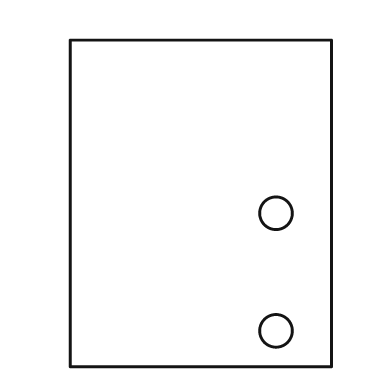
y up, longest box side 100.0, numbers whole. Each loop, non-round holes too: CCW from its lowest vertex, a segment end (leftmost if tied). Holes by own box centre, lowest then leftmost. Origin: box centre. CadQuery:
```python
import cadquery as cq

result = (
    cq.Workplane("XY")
    .moveTo(-40.0, -50.0)
    .lineTo(40.0, -50.0)
    .lineTo(40.0, 50.0)
    .lineTo(-40.0, 50.0)
    .close()
    .moveTo(23.0, -39.0)
    .circle(5.0)
    .moveTo(23.0, -3.0)
    .circle(5.0)
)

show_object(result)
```